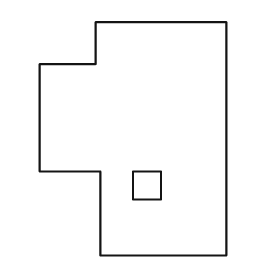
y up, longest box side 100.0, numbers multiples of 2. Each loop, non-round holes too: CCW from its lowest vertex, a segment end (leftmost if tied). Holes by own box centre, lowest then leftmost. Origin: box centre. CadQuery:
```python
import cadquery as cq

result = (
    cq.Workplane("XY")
    .moveTo(-14.0, -50.0)
    .lineTo(40.0, -50.0)
    .lineTo(40.0, 50.0)
    .lineTo(-16.0, 50.0)
    .lineTo(-16.0, 32.0)
    .lineTo(-40.0, 32.0)
    .lineTo(-40.0, -14.0)
    .lineTo(-14.0, -14.0)
    .close()
    .moveTo(0.0, -26.0)
    .lineTo(12.0, -26.0)
    .lineTo(12.0, -14.0)
    .lineTo(0.0, -14.0)
    .close()
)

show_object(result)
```